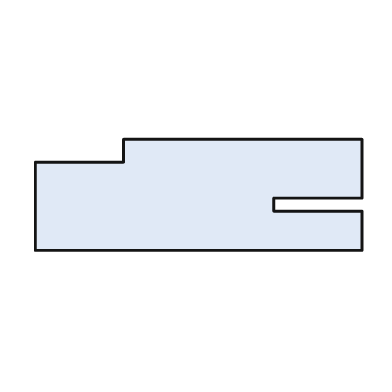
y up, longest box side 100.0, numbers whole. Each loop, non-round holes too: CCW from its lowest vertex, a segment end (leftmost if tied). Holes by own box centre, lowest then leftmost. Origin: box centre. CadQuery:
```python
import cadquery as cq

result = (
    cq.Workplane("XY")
    .moveTo(-50.0, -17.0)
    .lineTo(50.0, -17.0)
    .lineTo(50.0, -5.0)
    .lineTo(23.0, -5.0)
    .lineTo(23.0, -1.0)
    .lineTo(50.0, -1.0)
    .lineTo(50.0, 17.0)
    .lineTo(-23.0, 17.0)
    .lineTo(-23.0, 10.0)
    .lineTo(-50.0, 10.0)
    .close()
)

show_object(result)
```